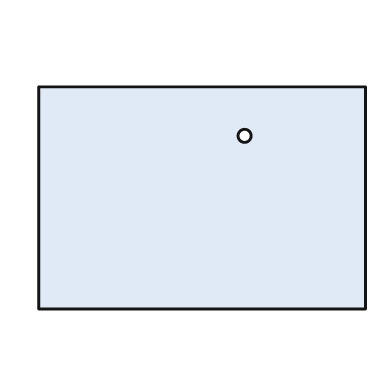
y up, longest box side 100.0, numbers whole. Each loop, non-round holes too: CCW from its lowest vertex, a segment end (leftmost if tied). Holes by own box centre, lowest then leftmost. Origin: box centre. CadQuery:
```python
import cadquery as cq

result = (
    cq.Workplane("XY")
    .moveTo(-50.0, -34.0)
    .lineTo(50.0, -34.0)
    .lineTo(50.0, 34.0)
    .lineTo(-50.0, 34.0)
    .close()
    .moveTo(13.0, 19.0)
    .circle(2.0)
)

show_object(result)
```